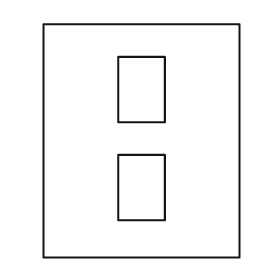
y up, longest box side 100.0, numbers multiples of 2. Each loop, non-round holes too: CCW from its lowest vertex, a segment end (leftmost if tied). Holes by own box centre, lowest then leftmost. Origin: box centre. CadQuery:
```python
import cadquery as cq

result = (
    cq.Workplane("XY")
    .moveTo(-42.0, -50.0)
    .lineTo(42.0, -50.0)
    .lineTo(42.0, 50.0)
    .lineTo(-42.0, 50.0)
    .close()
    .moveTo(-10.0, -34.0)
    .lineTo(10.0, -34.0)
    .lineTo(10.0, -6.0)
    .lineTo(-10.0, -6.0)
    .close()
    .moveTo(-10.0, 8.0)
    .lineTo(10.0, 8.0)
    .lineTo(10.0, 36.0)
    .lineTo(-10.0, 36.0)
    .close()
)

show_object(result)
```